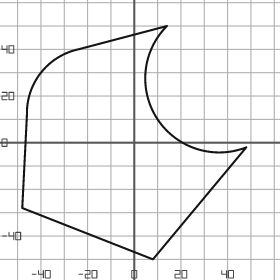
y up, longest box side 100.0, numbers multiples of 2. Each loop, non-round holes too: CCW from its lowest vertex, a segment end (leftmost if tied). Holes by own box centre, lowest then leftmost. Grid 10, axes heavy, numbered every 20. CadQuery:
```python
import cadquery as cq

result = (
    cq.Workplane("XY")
    .moveTo(8.0, -50.0)
    .lineTo(48.0, -2.0)
    .threePointArc((10.0, 10.0), (14.0, 50.0))
    .lineTo(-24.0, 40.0)
    .threePointArc((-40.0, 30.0), (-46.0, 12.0))
    .lineTo(-48.0, -28.0)
    .close()
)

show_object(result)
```